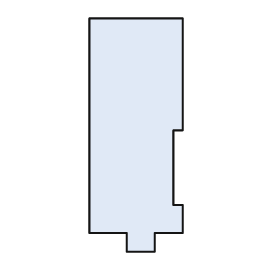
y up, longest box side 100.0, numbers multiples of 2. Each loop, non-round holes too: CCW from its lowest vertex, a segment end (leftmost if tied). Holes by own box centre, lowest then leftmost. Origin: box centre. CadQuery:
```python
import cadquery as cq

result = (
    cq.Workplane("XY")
    .moveTo(-4.0, -50.0)
    .lineTo(8.0, -50.0)
    .lineTo(8.0, -42.0)
    .lineTo(20.0, -42.0)
    .lineTo(20.0, -30.0)
    .lineTo(16.0, -30.0)
    .lineTo(16.0, 2.0)
    .lineTo(20.0, 2.0)
    .lineTo(20.0, 50.0)
    .lineTo(-20.0, 50.0)
    .lineTo(-20.0, -42.0)
    .lineTo(-4.0, -42.0)
    .close()
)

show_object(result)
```